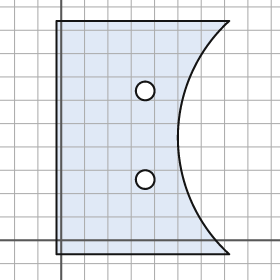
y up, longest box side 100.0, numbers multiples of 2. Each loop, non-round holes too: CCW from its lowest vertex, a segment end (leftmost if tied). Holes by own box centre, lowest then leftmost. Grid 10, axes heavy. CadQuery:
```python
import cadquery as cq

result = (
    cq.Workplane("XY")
    .moveTo(-2.0, -6.0)
    .lineTo(72.0, -6.0)
    .threePointArc((50.0, 44.0), (72.0, 94.0))
    .lineTo(-2.0, 94.0)
    .close()
    .moveTo(36.0, 26.0)
    .circle(4.0)
    .moveTo(36.0, 64.0)
    .circle(4.0)
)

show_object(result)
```